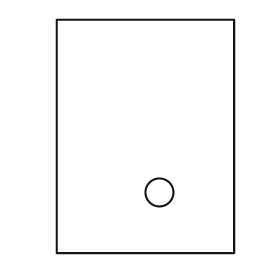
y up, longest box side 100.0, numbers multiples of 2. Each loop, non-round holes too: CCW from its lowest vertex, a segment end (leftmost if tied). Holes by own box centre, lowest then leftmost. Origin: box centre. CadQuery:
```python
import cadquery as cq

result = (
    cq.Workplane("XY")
    .moveTo(-38.0, -50.0)
    .lineTo(38.0, -50.0)
    .lineTo(38.0, 50.0)
    .lineTo(-38.0, 50.0)
    .close()
    .moveTo(6.0, -24.0)
    .circle(6.0)
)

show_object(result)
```